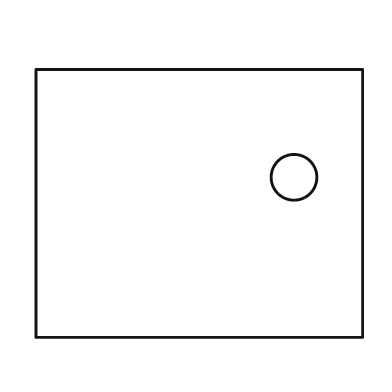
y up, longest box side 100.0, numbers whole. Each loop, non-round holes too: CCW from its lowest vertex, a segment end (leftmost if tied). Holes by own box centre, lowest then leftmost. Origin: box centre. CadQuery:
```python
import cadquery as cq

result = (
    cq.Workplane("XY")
    .moveTo(-50.0, -41.0)
    .lineTo(50.0, -41.0)
    .lineTo(50.0, 41.0)
    .lineTo(-50.0, 41.0)
    .close()
    .moveTo(29.0, 8.0)
    .circle(7.0)
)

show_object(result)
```